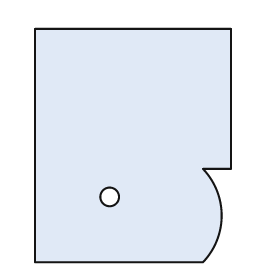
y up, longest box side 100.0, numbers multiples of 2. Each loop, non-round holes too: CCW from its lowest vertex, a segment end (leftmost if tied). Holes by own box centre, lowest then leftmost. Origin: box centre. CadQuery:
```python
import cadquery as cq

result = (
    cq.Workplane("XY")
    .moveTo(-42.0, -50.0)
    .lineTo(30.0, -50.0)
    .threePointArc((38.0, -30.0), (30.0, -10.0))
    .lineTo(42.0, -10.0)
    .lineTo(42.0, 50.0)
    .lineTo(-42.0, 50.0)
    .close()
    .moveTo(-10.0, -22.0)
    .circle(4.0)
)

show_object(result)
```